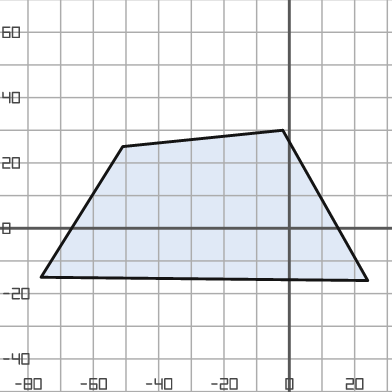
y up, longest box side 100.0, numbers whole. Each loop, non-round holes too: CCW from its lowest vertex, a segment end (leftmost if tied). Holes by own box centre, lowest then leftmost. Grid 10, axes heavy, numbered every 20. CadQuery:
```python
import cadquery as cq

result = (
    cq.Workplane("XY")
    .moveTo(24.0, -16.0)
    .lineTo(-2.0, 30.0)
    .lineTo(-51.0, 25.0)
    .lineTo(-76.0, -15.0)
    .close()
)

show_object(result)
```